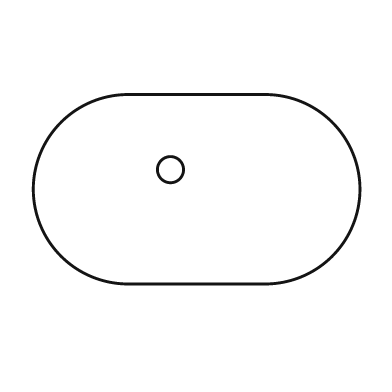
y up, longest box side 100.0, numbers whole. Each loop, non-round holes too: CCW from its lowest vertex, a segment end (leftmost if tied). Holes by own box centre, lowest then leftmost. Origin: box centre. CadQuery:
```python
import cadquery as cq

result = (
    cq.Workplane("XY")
    .moveTo(-21.0, -29.0)
    .lineTo(21.0, -29.0)
    .threePointArc((50.0, 0.0), (21.0, 29.0))
    .lineTo(-21.0, 29.0)
    .threePointArc((-50.0, 0.0), (-21.0, -29.0))
    .close()
    .moveTo(-8.0, 6.0)
    .circle(4.0)
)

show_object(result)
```